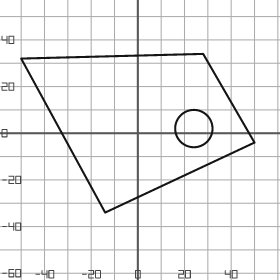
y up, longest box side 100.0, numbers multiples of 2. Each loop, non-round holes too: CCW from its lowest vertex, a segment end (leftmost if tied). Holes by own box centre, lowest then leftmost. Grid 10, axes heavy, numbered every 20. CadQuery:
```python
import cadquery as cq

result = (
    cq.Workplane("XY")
    .moveTo(-14.0, -34.0)
    .lineTo(50.0, -4.0)
    .lineTo(28.0, 34.0)
    .lineTo(-50.0, 32.0)
    .close()
    .moveTo(24.0, 2.0)
    .circle(8.0)
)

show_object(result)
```